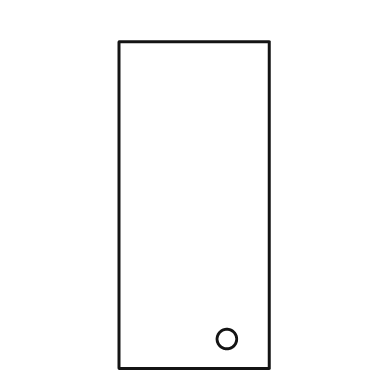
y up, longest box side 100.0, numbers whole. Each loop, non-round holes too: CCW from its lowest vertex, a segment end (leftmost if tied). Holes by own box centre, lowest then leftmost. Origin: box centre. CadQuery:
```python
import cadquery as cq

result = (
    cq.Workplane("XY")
    .moveTo(-23.0, -50.0)
    .lineTo(23.0, -50.0)
    .lineTo(23.0, 50.0)
    .lineTo(-23.0, 50.0)
    .close()
    .moveTo(10.0, -41.0)
    .circle(3.0)
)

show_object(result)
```